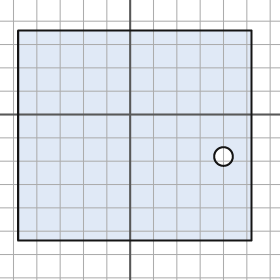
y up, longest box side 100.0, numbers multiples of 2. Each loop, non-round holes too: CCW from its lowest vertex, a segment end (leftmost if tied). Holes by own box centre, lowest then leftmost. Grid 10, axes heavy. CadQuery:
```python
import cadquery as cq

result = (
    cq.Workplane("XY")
    .moveTo(-48.0, -54.0)
    .lineTo(52.0, -54.0)
    .lineTo(52.0, 36.0)
    .lineTo(-48.0, 36.0)
    .close()
    .moveTo(40.0, -18.0)
    .circle(4.0)
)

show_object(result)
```